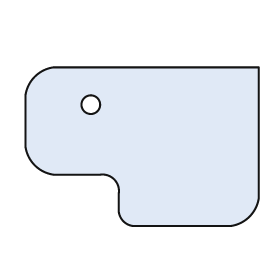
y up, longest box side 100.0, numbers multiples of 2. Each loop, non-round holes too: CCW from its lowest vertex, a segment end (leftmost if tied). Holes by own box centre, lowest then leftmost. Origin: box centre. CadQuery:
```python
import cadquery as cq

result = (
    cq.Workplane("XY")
    .moveTo(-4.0, -34.0)
    .lineTo(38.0, -34.0)
    .threePointArc((46.0, -30.0), (50.0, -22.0))
    .lineTo(50.0, 34.0)
    .lineTo(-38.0, 34.0)
    .threePointArc((-46.0, 30.0), (-50.0, 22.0))
    .lineTo(-50.0, 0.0)
    .threePointArc((-46.0, -8.0), (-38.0, -12.0))
    .lineTo(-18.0, -12.0)
    .threePointArc((-12.0, -14.0), (-10.0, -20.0))
    .lineTo(-10.0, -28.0)
    .threePointArc((-8.0, -32.0), (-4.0, -34.0))
    .close()
    .moveTo(-22.0, 18.0)
    .circle(4.0)
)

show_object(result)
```